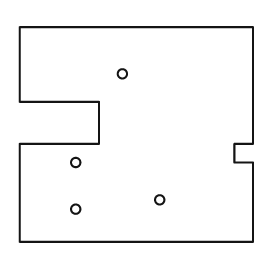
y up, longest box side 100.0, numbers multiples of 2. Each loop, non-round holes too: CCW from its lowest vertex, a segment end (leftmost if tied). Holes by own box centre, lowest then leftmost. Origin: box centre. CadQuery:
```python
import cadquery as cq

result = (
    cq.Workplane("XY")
    .moveTo(-50.0, -46.0)
    .lineTo(50.0, -46.0)
    .lineTo(50.0, -12.0)
    .lineTo(42.0, -12.0)
    .lineTo(42.0, -4.0)
    .lineTo(50.0, -4.0)
    .lineTo(50.0, 46.0)
    .lineTo(-50.0, 46.0)
    .lineTo(-50.0, 14.0)
    .lineTo(-16.0, 14.0)
    .lineTo(-16.0, -4.0)
    .lineTo(-50.0, -4.0)
    .close()
    .moveTo(-26.0, -32.0)
    .circle(2.0)
    .moveTo(10.0, -28.0)
    .circle(2.0)
    .moveTo(-26.0, -12.0)
    .circle(2.0)
    .moveTo(-6.0, 26.0)
    .circle(2.0)
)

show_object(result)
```